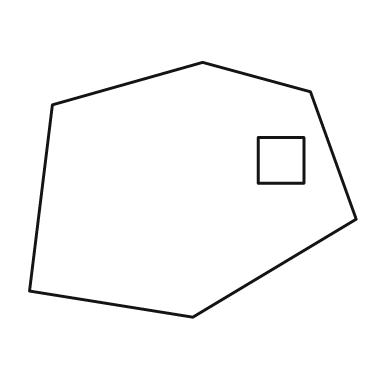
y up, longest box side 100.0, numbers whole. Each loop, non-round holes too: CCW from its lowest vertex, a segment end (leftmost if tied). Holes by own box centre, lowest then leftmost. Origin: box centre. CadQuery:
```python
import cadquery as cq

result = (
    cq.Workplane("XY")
    .moveTo(0.0, -39.0)
    .lineTo(50.0, -9.0)
    .lineTo(36.0, 30.0)
    .lineTo(3.0, 39.0)
    .lineTo(-43.0, 26.0)
    .lineTo(-50.0, -31.0)
    .close()
    .moveTo(20.0, 2.0)
    .lineTo(34.0, 2.0)
    .lineTo(34.0, 16.0)
    .lineTo(20.0, 16.0)
    .close()
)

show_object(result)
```